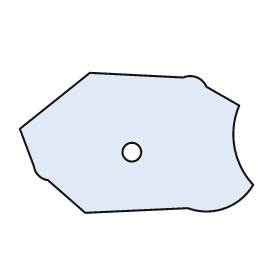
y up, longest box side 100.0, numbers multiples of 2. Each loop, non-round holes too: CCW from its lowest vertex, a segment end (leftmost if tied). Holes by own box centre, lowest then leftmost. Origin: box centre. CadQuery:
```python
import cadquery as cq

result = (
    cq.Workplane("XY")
    .moveTo(-22.0, -30.0)
    .lineTo(22.0, -28.0)
    .threePointArc((38.0, -28.0), (50.0, -18.0))
    .threePointArc((42.0, -2.0), (44.0, 16.0))
    .lineTo(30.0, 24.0)
    .threePointArc((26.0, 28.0), (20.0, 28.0))
    .lineTo(-20.0, 30.0)
    .lineTo(-50.0, 6.0)
    .lineTo(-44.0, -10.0)
    .threePointArc((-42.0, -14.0), (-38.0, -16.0))
    .close()
    .moveTo(-2.0, -4.0)
    .circle(4.0)
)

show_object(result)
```